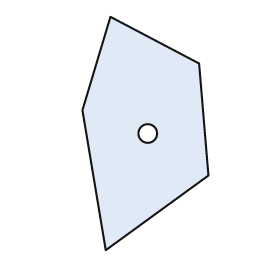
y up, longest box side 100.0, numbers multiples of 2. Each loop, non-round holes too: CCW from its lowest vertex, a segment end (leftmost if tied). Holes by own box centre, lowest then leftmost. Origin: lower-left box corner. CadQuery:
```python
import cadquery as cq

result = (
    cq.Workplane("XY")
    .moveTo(10.0, 0.0)
    .lineTo(54.0, 32.0)
    .lineTo(50.0, 80.0)
    .lineTo(12.0, 100.0)
    .lineTo(0.0, 60.0)
    .close()
    .moveTo(28.0, 50.0)
    .circle(4.0)
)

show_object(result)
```